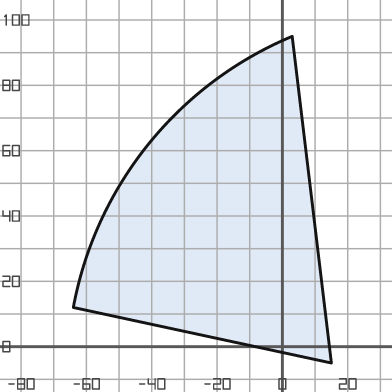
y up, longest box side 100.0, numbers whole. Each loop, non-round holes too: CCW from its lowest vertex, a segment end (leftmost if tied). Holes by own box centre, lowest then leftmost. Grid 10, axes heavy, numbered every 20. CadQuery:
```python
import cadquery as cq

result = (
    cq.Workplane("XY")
    .moveTo(15.0, -5.0)
    .lineTo(3.0, 95.0)
    .threePointArc((-41.0, 62.0), (-64.0, 12.0))
    .close()
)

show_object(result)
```